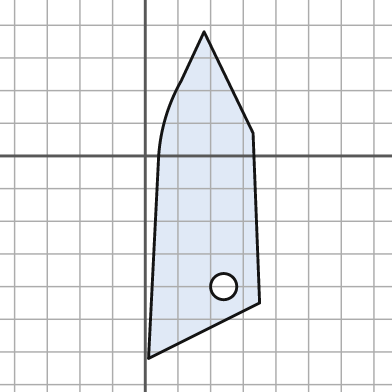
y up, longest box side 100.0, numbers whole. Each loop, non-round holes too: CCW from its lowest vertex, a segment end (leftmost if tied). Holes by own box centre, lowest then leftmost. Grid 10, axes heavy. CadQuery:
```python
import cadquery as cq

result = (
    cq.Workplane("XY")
    .moveTo(1.0, -62.0)
    .lineTo(35.0, -45.0)
    .lineTo(33.0, 7.0)
    .lineTo(18.0, 38.0)
    .lineTo(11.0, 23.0)
    .threePointArc((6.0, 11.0), (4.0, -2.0))
    .close()
    .moveTo(24.0, -40.0)
    .circle(4.0)
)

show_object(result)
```